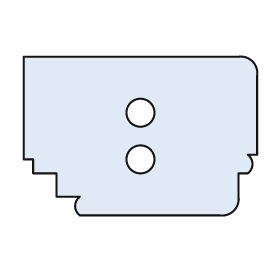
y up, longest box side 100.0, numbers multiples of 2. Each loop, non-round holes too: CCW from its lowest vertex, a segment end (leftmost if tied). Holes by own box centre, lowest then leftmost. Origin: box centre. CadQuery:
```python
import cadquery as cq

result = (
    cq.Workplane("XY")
    .moveTo(-26.0, -34.0)
    .lineTo(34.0, -34.0)
    .threePointArc((40.0, -32.0), (42.0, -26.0))
    .lineTo(42.0, -16.0)
    .lineTo(46.0, -16.0)
    .threePointArc((48.0, -12.0), (46.0, -8.0))
    .lineTo(50.0, -8.0)
    .lineTo(50.0, 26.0)
    .threePointArc((48.0, 32.0), (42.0, 34.0))
    .lineTo(-50.0, 34.0)
    .lineTo(-50.0, -10.0)
    .lineTo(-46.0, -10.0)
    .lineTo(-46.0, -16.0)
    .lineTo(-36.0, -16.0)
    .lineTo(-36.0, -26.0)
    .lineTo(-26.0, -26.0)
    .threePointArc((-28.0, -30.0), (-26.0, -34.0))
    .close()
    .moveTo(0.0, -10.0)
    .circle(6.0)
    .moveTo(0.0, 10.0)
    .circle(6.0)
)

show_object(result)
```